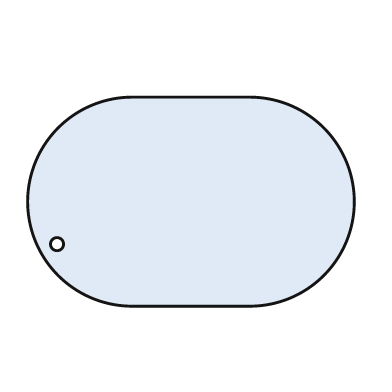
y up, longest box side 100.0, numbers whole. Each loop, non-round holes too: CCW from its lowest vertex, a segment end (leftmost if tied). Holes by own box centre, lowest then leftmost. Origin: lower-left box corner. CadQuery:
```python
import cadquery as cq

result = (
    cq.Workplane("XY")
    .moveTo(32.0, 0.0)
    .lineTo(68.0, 0.0)
    .threePointArc((100.0, 32.0), (68.0, 64.0))
    .lineTo(32.0, 64.0)
    .threePointArc((0.0, 32.0), (32.0, 0.0))
    .close()
    .moveTo(9.0, 19.0)
    .circle(2.0)
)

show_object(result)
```